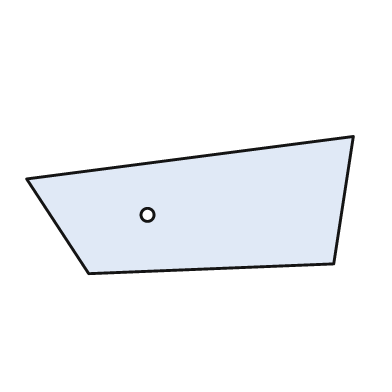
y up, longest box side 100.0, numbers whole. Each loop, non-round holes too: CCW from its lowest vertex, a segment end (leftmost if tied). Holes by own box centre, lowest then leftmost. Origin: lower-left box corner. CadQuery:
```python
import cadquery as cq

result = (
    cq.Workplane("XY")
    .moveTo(19.0, 0.0)
    .lineTo(94.0, 3.0)
    .lineTo(100.0, 42.0)
    .lineTo(0.0, 29.0)
    .close()
    .moveTo(37.0, 18.0)
    .circle(2.0)
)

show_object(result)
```